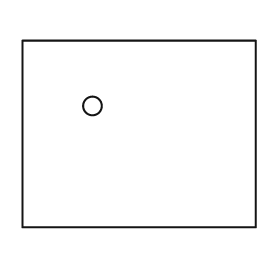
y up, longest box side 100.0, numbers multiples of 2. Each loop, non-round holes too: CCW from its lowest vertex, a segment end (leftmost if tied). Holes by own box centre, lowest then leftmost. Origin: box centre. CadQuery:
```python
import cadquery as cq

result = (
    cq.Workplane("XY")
    .moveTo(-50.0, -40.0)
    .lineTo(50.0, -40.0)
    .lineTo(50.0, 40.0)
    .lineTo(-50.0, 40.0)
    .close()
    .moveTo(-20.0, 12.0)
    .circle(4.0)
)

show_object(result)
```